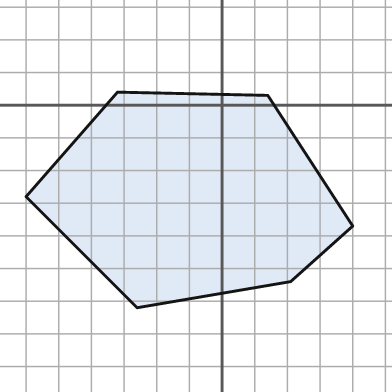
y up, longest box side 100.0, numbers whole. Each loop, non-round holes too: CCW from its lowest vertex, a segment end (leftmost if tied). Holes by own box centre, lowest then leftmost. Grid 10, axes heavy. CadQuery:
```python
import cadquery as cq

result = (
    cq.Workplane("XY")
    .moveTo(-26.0, -62.0)
    .lineTo(21.0, -54.0)
    .lineTo(40.0, -37.0)
    .lineTo(14.0, 3.0)
    .lineTo(-32.0, 4.0)
    .lineTo(-60.0, -28.0)
    .close()
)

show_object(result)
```